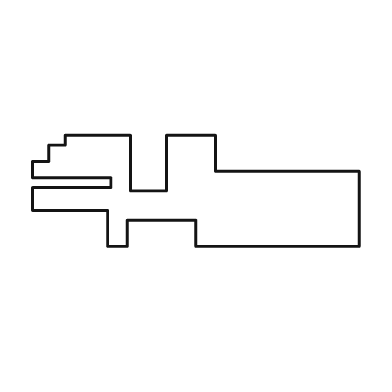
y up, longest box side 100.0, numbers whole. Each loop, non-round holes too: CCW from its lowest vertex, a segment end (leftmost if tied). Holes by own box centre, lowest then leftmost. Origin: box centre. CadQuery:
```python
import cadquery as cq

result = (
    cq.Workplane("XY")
    .moveTo(-27.0, -17.0)
    .lineTo(-21.0, -17.0)
    .lineTo(-21.0, -9.0)
    .lineTo(0.0, -9.0)
    .lineTo(0.0, -17.0)
    .lineTo(50.0, -17.0)
    .lineTo(50.0, 6.0)
    .lineTo(6.0, 6.0)
    .lineTo(6.0, 17.0)
    .lineTo(-9.0, 17.0)
    .lineTo(-9.0, 0.0)
    .lineTo(-20.0, 0.0)
    .lineTo(-20.0, 17.0)
    .lineTo(-40.0, 17.0)
    .lineTo(-40.0, 14.0)
    .lineTo(-45.0, 14.0)
    .lineTo(-45.0, 9.0)
    .lineTo(-50.0, 9.0)
    .lineTo(-50.0, 4.0)
    .lineTo(-26.0, 4.0)
    .lineTo(-26.0, 1.0)
    .lineTo(-50.0, 1.0)
    .lineTo(-50.0, -6.0)
    .lineTo(-27.0, -6.0)
    .close()
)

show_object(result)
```